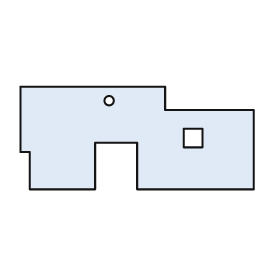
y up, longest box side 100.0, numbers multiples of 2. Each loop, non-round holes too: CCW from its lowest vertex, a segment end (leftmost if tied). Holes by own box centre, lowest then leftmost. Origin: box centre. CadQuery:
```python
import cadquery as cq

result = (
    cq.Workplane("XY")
    .moveTo(-46.0, -22.0)
    .lineTo(-18.0, -22.0)
    .lineTo(-18.0, -2.0)
    .lineTo(0.0, -2.0)
    .lineTo(0.0, -22.0)
    .lineTo(50.0, -22.0)
    .lineTo(50.0, 12.0)
    .lineTo(12.0, 12.0)
    .lineTo(12.0, 22.0)
    .lineTo(-50.0, 22.0)
    .lineTo(-50.0, -6.0)
    .lineTo(-46.0, -6.0)
    .close()
    .moveTo(20.0, -4.0)
    .lineTo(28.0, -4.0)
    .lineTo(28.0, 4.0)
    .lineTo(20.0, 4.0)
    .close()
    .moveTo(-12.0, 16.0)
    .circle(2.0)
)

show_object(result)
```